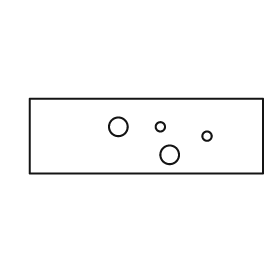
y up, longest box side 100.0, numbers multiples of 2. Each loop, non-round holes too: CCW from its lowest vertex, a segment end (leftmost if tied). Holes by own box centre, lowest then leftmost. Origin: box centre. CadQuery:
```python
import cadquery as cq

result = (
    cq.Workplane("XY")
    .moveTo(-50.0, -16.0)
    .lineTo(50.0, -16.0)
    .lineTo(50.0, 16.0)
    .lineTo(-50.0, 16.0)
    .close()
    .moveTo(10.0, -8.0)
    .circle(4.0)
    .moveTo(26.0, 0.0)
    .circle(2.0)
    .moveTo(-12.0, 4.0)
    .circle(4.0)
    .moveTo(6.0, 4.0)
    .circle(2.0)
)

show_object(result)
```